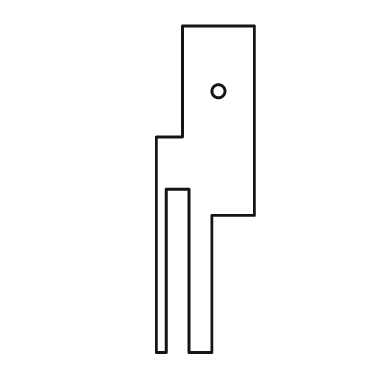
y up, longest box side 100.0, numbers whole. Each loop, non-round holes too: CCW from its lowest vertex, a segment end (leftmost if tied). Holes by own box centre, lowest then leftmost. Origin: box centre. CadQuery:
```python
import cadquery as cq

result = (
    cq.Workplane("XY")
    .moveTo(-15.0, -50.0)
    .lineTo(-12.0, -50.0)
    .lineTo(-12.0, 0.0)
    .lineTo(-5.0, 0.0)
    .lineTo(-5.0, -50.0)
    .lineTo(2.0, -50.0)
    .lineTo(2.0, -8.0)
    .lineTo(15.0, -8.0)
    .lineTo(15.0, 50.0)
    .lineTo(-7.0, 50.0)
    .lineTo(-7.0, 16.0)
    .lineTo(-15.0, 16.0)
    .close()
    .moveTo(4.0, 30.0)
    .circle(2.0)
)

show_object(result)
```